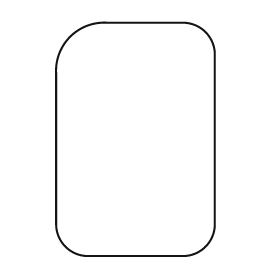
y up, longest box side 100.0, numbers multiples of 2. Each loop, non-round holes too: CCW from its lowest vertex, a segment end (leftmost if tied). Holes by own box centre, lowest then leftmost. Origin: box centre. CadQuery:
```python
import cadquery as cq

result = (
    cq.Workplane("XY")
    .moveTo(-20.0, -50.0)
    .lineTo(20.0, -50.0)
    .threePointArc((30.0, -46.0), (34.0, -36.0))
    .lineTo(34.0, 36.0)
    .threePointArc((30.0, 46.0), (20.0, 50.0))
    .lineTo(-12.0, 50.0)
    .threePointArc((-28.0, 44.0), (-34.0, 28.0))
    .lineTo(-34.0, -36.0)
    .threePointArc((-30.0, -46.0), (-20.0, -50.0))
    .close()
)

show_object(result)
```